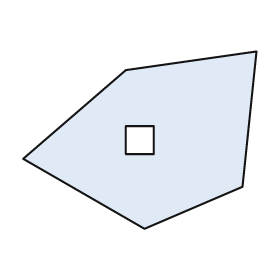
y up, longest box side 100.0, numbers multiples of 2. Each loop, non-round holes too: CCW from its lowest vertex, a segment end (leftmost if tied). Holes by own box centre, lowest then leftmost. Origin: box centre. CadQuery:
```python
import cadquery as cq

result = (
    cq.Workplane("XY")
    .moveTo(2.0, -38.0)
    .lineTo(44.0, -20.0)
    .lineTo(50.0, 38.0)
    .lineTo(-6.0, 30.0)
    .lineTo(-50.0, -8.0)
    .close()
    .moveTo(-6.0, -6.0)
    .lineTo(6.0, -6.0)
    .lineTo(6.0, 6.0)
    .lineTo(-6.0, 6.0)
    .close()
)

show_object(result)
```